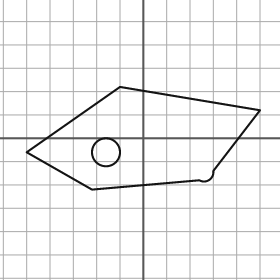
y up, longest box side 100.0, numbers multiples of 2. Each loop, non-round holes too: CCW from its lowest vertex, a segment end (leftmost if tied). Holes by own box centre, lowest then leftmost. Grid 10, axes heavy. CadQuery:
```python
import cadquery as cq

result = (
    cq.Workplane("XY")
    .moveTo(-22.0, -22.0)
    .lineTo(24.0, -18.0)
    .threePointArc((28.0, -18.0), (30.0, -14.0))
    .lineTo(50.0, 12.0)
    .lineTo(-10.0, 22.0)
    .lineTo(-50.0, -6.0)
    .close()
    .moveTo(-16.0, -6.0)
    .circle(6.0)
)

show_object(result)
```